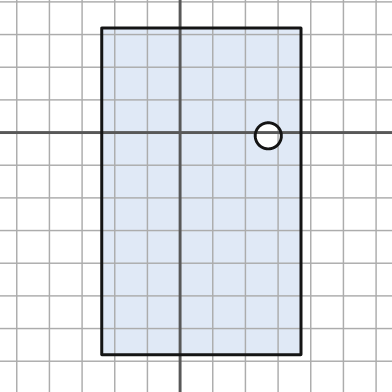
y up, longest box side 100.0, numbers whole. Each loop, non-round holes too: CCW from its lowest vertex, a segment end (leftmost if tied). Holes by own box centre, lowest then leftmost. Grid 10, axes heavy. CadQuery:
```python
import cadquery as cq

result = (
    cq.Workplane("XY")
    .moveTo(-24.0, -68.0)
    .lineTo(37.0, -68.0)
    .lineTo(37.0, 32.0)
    .lineTo(-24.0, 32.0)
    .close()
    .moveTo(27.0, -1.0)
    .circle(4.0)
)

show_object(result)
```